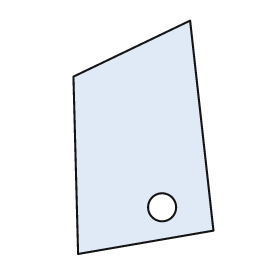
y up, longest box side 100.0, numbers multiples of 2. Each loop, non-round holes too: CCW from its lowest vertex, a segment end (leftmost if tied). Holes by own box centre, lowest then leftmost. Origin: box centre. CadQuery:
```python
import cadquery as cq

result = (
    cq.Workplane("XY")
    .moveTo(-28.0, -50.0)
    .lineTo(30.0, -40.0)
    .lineTo(20.0, 50.0)
    .lineTo(-30.0, 26.0)
    .close()
    .moveTo(8.0, -30.0)
    .circle(6.0)
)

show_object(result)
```